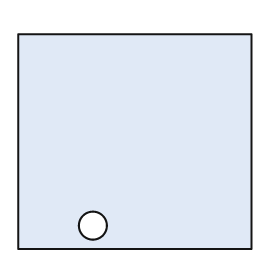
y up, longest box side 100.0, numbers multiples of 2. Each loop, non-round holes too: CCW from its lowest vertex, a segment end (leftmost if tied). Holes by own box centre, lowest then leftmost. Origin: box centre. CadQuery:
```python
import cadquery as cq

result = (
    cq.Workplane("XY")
    .moveTo(-50.0, -46.0)
    .lineTo(50.0, -46.0)
    .lineTo(50.0, 46.0)
    .lineTo(-50.0, 46.0)
    .close()
    .moveTo(-18.0, -36.0)
    .circle(6.0)
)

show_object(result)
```